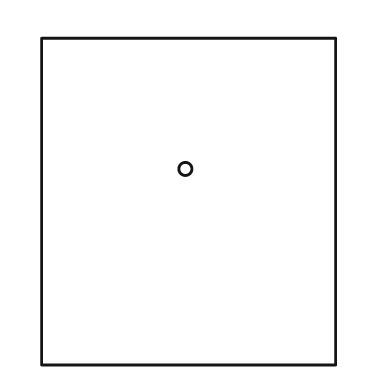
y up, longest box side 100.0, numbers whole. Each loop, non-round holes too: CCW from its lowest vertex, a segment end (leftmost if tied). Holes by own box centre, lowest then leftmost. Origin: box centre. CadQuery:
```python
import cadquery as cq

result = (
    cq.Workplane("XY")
    .moveTo(-45.0, -50.0)
    .lineTo(45.0, -50.0)
    .lineTo(45.0, 50.0)
    .lineTo(-45.0, 50.0)
    .close()
    .moveTo(-1.0, 10.0)
    .circle(2.0)
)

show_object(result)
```